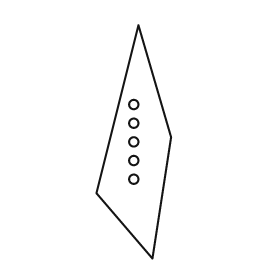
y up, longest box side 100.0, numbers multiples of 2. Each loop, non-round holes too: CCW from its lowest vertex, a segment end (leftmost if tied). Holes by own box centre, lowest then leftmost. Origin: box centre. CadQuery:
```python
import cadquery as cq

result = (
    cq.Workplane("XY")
    .moveTo(8.0, -50.0)
    .lineTo(16.0, 2.0)
    .lineTo(2.0, 50.0)
    .lineTo(-16.0, -22.0)
    .close()
    .moveTo(0.0, -16.0)
    .circle(2.0)
    .moveTo(0.0, -8.0)
    .circle(2.0)
    .moveTo(0.0, 0.0)
    .circle(2.0)
    .moveTo(0.0, 8.0)
    .circle(2.0)
    .moveTo(0.0, 16.0)
    .circle(2.0)
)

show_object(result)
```